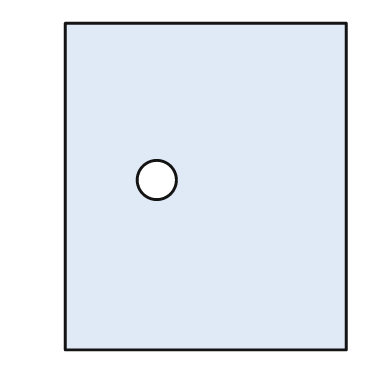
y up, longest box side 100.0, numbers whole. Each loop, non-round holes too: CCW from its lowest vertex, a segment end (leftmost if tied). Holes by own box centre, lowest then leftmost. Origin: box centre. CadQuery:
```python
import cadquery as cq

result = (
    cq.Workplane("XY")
    .moveTo(-43.0, -50.0)
    .lineTo(43.0, -50.0)
    .lineTo(43.0, 50.0)
    .lineTo(-43.0, 50.0)
    .close()
    .moveTo(-15.0, 2.0)
    .circle(6.0)
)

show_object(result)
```